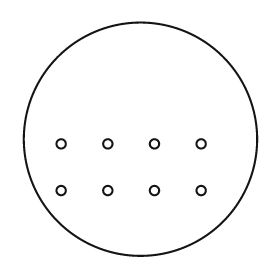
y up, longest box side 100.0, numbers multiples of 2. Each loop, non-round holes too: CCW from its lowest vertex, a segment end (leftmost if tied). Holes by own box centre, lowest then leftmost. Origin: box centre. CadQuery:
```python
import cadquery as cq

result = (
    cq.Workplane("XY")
    .moveTo(0.0, 0.0)
    .circle(50.0)
    .moveTo(-34.0, -22.0)
    .circle(2.0)
    .moveTo(-14.0, -22.0)
    .circle(2.0)
    .moveTo(6.0, -22.0)
    .circle(2.0)
    .moveTo(26.0, -22.0)
    .circle(2.0)
    .moveTo(-34.0, -2.0)
    .circle(2.0)
    .moveTo(-14.0, -2.0)
    .circle(2.0)
    .moveTo(6.0, -2.0)
    .circle(2.0)
    .moveTo(26.0, -2.0)
    .circle(2.0)
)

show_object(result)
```